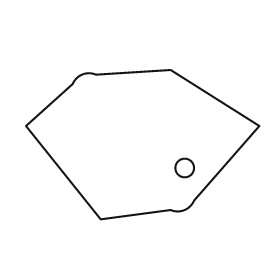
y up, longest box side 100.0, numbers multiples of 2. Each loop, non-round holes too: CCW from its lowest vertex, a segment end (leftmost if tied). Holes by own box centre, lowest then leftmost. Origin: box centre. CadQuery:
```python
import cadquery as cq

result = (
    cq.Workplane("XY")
    .moveTo(-18.0, -32.0)
    .lineTo(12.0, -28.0)
    .threePointArc((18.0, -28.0), (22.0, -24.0))
    .lineTo(50.0, 8.0)
    .lineTo(12.0, 32.0)
    .lineTo(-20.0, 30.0)
    .threePointArc((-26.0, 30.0), (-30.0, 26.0))
    .lineTo(-50.0, 8.0)
    .close()
    .moveTo(18.0, -10.0)
    .circle(4.0)
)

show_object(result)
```